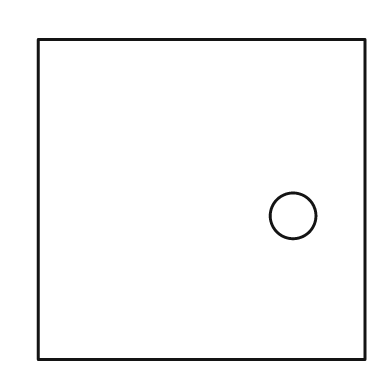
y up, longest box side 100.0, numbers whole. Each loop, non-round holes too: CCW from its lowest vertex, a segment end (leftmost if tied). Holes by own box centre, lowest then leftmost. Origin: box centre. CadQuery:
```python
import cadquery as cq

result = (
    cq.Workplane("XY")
    .moveTo(-50.0, -49.0)
    .lineTo(50.0, -49.0)
    .lineTo(50.0, 49.0)
    .lineTo(-50.0, 49.0)
    .close()
    .moveTo(28.0, -5.0)
    .circle(7.0)
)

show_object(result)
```